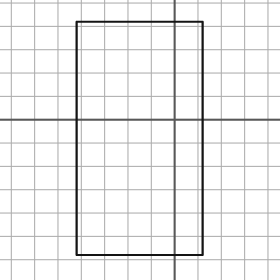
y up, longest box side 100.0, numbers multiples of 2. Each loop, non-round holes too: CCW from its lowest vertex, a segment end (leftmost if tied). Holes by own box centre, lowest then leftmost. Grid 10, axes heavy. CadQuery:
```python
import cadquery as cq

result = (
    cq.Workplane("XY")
    .moveTo(-42.0, -58.0)
    .lineTo(12.0, -58.0)
    .lineTo(12.0, 42.0)
    .lineTo(-42.0, 42.0)
    .close()
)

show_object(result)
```